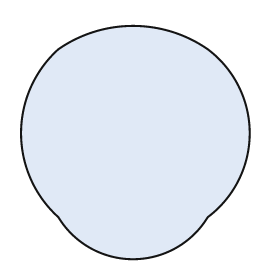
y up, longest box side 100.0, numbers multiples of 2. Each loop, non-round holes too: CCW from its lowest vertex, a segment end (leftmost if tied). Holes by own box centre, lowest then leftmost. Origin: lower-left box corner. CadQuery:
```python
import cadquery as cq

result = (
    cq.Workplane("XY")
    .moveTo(16.0, 18.0)
    .threePointArc((48.0, 0.0), (80.0, 18.0))
    .threePointArc((98.0, 54.0), (80.0, 90.0))
    .threePointArc((48.0, 100.0), (16.0, 90.0))
    .threePointArc((0.0, 54.0), (16.0, 18.0))
    .close()
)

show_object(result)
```